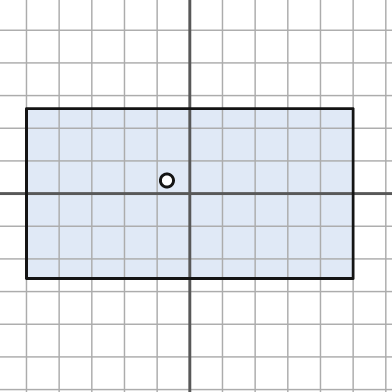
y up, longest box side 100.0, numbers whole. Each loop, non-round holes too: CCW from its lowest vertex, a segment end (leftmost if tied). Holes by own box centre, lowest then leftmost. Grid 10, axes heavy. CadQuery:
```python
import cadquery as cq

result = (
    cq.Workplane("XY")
    .moveTo(-50.0, -26.0)
    .lineTo(50.0, -26.0)
    .lineTo(50.0, 26.0)
    .lineTo(-50.0, 26.0)
    .close()
    .moveTo(-7.0, 4.0)
    .circle(2.0)
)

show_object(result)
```